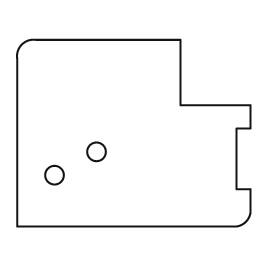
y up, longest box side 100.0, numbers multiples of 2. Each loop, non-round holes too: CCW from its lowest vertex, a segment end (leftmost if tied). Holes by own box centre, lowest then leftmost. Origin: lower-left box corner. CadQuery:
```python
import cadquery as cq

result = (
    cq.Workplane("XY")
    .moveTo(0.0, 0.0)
    .lineTo(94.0, 0.0)
    .threePointArc((98.0, 2.0), (100.0, 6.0))
    .lineTo(100.0, 16.0)
    .lineTo(94.0, 16.0)
    .lineTo(94.0, 42.0)
    .lineTo(100.0, 42.0)
    .lineTo(100.0, 52.0)
    .lineTo(70.0, 52.0)
    .lineTo(70.0, 80.0)
    .lineTo(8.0, 80.0)
    .threePointArc((2.0, 78.0), (0.0, 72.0))
    .close()
    .moveTo(16.0, 22.0)
    .circle(4.0)
    .moveTo(34.0, 32.0)
    .circle(4.0)
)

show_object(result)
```